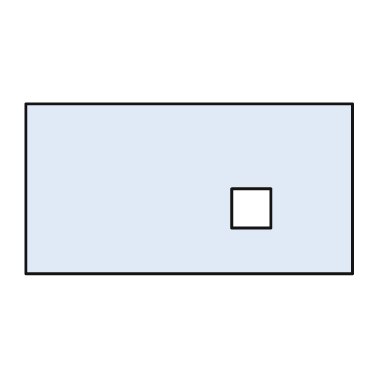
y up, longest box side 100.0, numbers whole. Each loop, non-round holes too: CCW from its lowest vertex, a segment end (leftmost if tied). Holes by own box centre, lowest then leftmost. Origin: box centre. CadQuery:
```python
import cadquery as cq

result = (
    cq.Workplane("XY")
    .moveTo(-50.0, -26.0)
    .lineTo(50.0, -26.0)
    .lineTo(50.0, 26.0)
    .lineTo(-50.0, 26.0)
    .close()
    .moveTo(13.0, -12.0)
    .lineTo(25.0, -12.0)
    .lineTo(25.0, 0.0)
    .lineTo(13.0, 0.0)
    .close()
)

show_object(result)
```